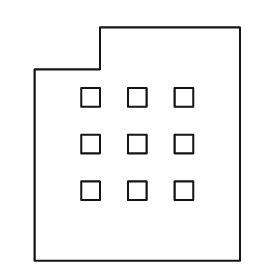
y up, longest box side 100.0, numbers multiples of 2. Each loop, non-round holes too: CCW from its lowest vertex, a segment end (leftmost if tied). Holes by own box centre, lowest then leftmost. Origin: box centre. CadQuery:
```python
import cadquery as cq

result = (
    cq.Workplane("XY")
    .moveTo(-44.0, -50.0)
    .lineTo(44.0, -50.0)
    .lineTo(44.0, 50.0)
    .lineTo(-16.0, 50.0)
    .lineTo(-16.0, 32.0)
    .lineTo(-44.0, 32.0)
    .close()
    .moveTo(-24.0, -24.0)
    .lineTo(-16.0, -24.0)
    .lineTo(-16.0, -16.0)
    .lineTo(-24.0, -16.0)
    .close()
    .moveTo(-4.0, -24.0)
    .lineTo(4.0, -24.0)
    .lineTo(4.0, -16.0)
    .lineTo(-4.0, -16.0)
    .close()
    .moveTo(16.0, -24.0)
    .lineTo(24.0, -24.0)
    .lineTo(24.0, -16.0)
    .lineTo(16.0, -16.0)
    .close()
    .moveTo(-24.0, -4.0)
    .lineTo(-16.0, -4.0)
    .lineTo(-16.0, 4.0)
    .lineTo(-24.0, 4.0)
    .close()
    .moveTo(-4.0, -4.0)
    .lineTo(4.0, -4.0)
    .lineTo(4.0, 4.0)
    .lineTo(-4.0, 4.0)
    .close()
    .moveTo(16.0, -4.0)
    .lineTo(24.0, -4.0)
    .lineTo(24.0, 4.0)
    .lineTo(16.0, 4.0)
    .close()
    .moveTo(-24.0, 16.0)
    .lineTo(-16.0, 16.0)
    .lineTo(-16.0, 24.0)
    .lineTo(-24.0, 24.0)
    .close()
    .moveTo(-4.0, 16.0)
    .lineTo(4.0, 16.0)
    .lineTo(4.0, 24.0)
    .lineTo(-4.0, 24.0)
    .close()
    .moveTo(16.0, 16.0)
    .lineTo(24.0, 16.0)
    .lineTo(24.0, 24.0)
    .lineTo(16.0, 24.0)
    .close()
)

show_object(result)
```